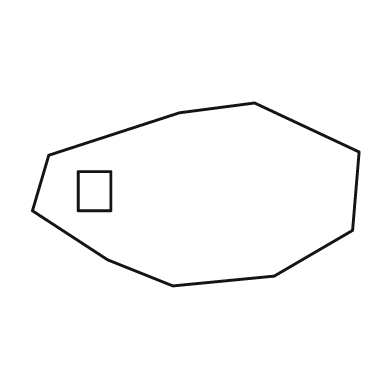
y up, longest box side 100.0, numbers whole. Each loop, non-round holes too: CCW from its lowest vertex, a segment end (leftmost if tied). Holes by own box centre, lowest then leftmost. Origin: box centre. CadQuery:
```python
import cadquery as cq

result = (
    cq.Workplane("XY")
    .moveTo(-7.0, -28.0)
    .lineTo(24.0, -25.0)
    .lineTo(48.0, -11.0)
    .lineTo(50.0, 13.0)
    .lineTo(18.0, 28.0)
    .lineTo(-5.0, 25.0)
    .lineTo(-45.0, 12.0)
    .lineTo(-50.0, -5.0)
    .lineTo(-27.0, -20.0)
    .close()
    .moveTo(-36.0, -5.0)
    .lineTo(-26.0, -5.0)
    .lineTo(-26.0, 7.0)
    .lineTo(-36.0, 7.0)
    .close()
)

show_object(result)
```